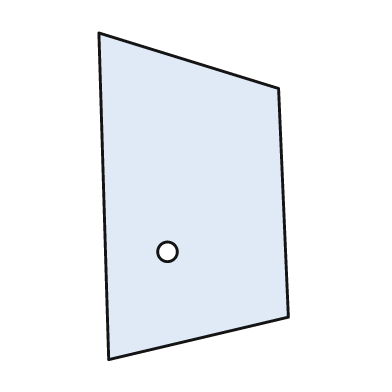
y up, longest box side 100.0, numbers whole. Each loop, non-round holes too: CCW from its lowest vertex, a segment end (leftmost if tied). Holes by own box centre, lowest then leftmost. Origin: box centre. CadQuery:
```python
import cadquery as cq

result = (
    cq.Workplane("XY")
    .moveTo(-26.0, -50.0)
    .lineTo(29.0, -37.0)
    .lineTo(26.0, 33.0)
    .lineTo(-29.0, 50.0)
    .close()
    .moveTo(-8.0, -17.0)
    .circle(3.0)
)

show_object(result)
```